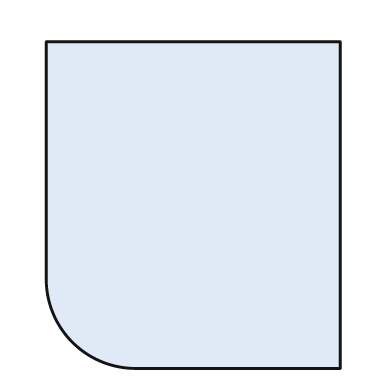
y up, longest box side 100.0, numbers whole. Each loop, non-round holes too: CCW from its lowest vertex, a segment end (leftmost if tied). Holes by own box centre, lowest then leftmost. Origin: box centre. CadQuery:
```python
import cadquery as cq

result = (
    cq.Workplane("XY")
    .moveTo(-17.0, -50.0)
    .lineTo(45.0, -50.0)
    .lineTo(45.0, 50.0)
    .lineTo(-45.0, 50.0)
    .lineTo(-45.0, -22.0)
    .threePointArc((-37.0, -42.0), (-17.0, -50.0))
    .close()
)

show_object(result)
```